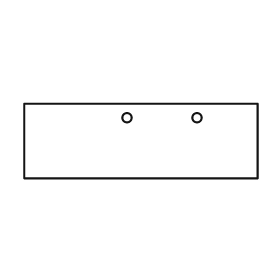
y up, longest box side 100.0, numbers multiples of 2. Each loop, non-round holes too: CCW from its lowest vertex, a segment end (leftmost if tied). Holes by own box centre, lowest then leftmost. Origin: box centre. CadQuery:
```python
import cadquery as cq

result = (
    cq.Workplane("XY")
    .moveTo(-50.0, -16.0)
    .lineTo(50.0, -16.0)
    .lineTo(50.0, 16.0)
    .lineTo(-50.0, 16.0)
    .close()
    .moveTo(-6.0, 10.0)
    .circle(2.0)
    .moveTo(24.0, 10.0)
    .circle(2.0)
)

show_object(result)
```